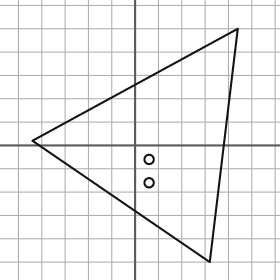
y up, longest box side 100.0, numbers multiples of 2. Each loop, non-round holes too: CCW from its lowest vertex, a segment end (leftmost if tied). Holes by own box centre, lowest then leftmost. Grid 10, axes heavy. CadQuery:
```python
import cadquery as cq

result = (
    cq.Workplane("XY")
    .moveTo(32.0, -50.0)
    .lineTo(44.0, 50.0)
    .lineTo(-44.0, 2.0)
    .close()
    .moveTo(6.0, -16.0)
    .circle(2.0)
    .moveTo(6.0, -6.0)
    .circle(2.0)
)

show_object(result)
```